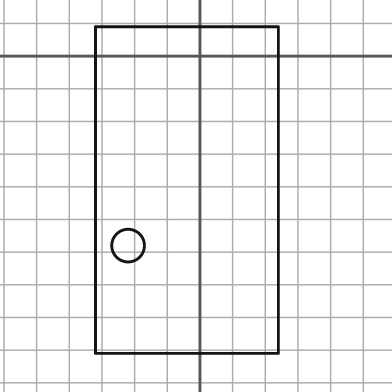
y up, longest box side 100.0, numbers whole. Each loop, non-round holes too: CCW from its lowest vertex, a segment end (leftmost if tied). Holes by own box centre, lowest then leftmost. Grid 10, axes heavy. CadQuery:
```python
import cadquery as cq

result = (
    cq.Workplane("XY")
    .moveTo(-32.0, -91.0)
    .lineTo(24.0, -91.0)
    .lineTo(24.0, 9.0)
    .lineTo(-32.0, 9.0)
    .close()
    .moveTo(-22.0, -58.0)
    .circle(5.0)
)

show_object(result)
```